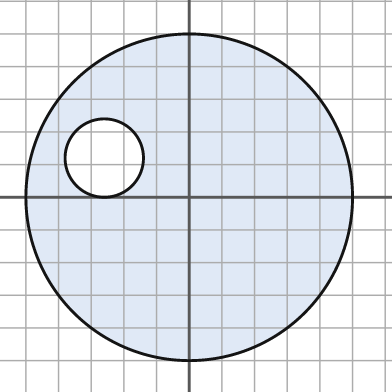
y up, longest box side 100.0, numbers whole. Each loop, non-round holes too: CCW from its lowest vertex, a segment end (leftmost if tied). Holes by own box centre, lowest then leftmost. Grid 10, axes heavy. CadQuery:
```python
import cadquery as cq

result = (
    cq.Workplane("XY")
    .moveTo(0.0, 0.0)
    .circle(50.0)
    .moveTo(-26.0, 12.0)
    .circle(12.0)
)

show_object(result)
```